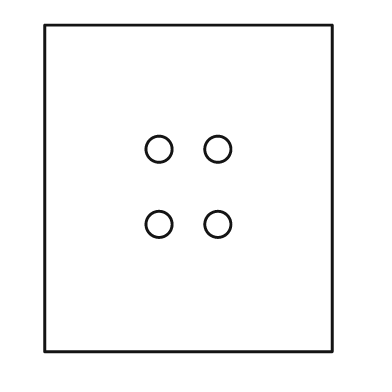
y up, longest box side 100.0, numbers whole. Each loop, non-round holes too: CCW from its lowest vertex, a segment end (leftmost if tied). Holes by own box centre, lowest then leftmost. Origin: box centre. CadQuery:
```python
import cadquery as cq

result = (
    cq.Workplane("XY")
    .moveTo(-44.0, -50.0)
    .lineTo(44.0, -50.0)
    .lineTo(44.0, 50.0)
    .lineTo(-44.0, 50.0)
    .close()
    .moveTo(-9.0, -11.0)
    .circle(4.0)
    .moveTo(9.0, -11.0)
    .circle(4.0)
    .moveTo(-9.0, 12.0)
    .circle(4.0)
    .moveTo(9.0, 12.0)
    .circle(4.0)
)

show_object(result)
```